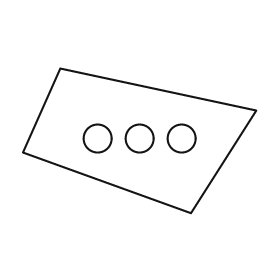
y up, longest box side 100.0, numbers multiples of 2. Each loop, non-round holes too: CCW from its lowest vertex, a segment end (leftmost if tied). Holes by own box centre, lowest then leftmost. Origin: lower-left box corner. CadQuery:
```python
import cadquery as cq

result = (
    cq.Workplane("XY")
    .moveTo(72.0, 0.0)
    .lineTo(100.0, 44.0)
    .lineTo(16.0, 62.0)
    .lineTo(0.0, 26.0)
    .close()
    .moveTo(32.0, 32.0)
    .circle(6.0)
    .moveTo(50.0, 32.0)
    .circle(6.0)
    .moveTo(68.0, 32.0)
    .circle(6.0)
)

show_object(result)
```